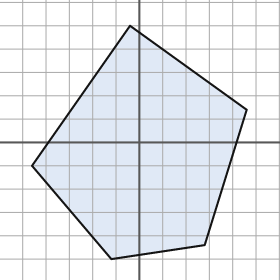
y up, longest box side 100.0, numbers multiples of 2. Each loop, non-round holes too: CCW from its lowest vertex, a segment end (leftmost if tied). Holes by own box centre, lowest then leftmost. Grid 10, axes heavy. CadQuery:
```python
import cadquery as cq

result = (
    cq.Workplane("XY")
    .moveTo(-12.0, -50.0)
    .lineTo(28.0, -44.0)
    .lineTo(46.0, 14.0)
    .lineTo(-4.0, 50.0)
    .lineTo(-46.0, -10.0)
    .close()
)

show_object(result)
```